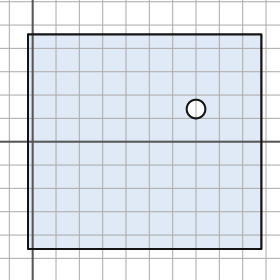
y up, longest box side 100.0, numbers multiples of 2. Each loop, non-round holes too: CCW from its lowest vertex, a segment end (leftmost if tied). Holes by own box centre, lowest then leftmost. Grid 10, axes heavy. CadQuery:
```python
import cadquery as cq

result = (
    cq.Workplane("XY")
    .moveTo(-2.0, -46.0)
    .lineTo(98.0, -46.0)
    .lineTo(98.0, 46.0)
    .lineTo(-2.0, 46.0)
    .close()
    .moveTo(70.0, 14.0)
    .circle(4.0)
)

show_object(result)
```